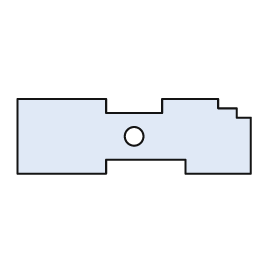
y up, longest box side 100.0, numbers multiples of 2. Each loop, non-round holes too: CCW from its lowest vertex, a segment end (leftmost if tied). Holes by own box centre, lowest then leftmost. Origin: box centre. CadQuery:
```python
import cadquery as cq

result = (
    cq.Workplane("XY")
    .moveTo(-50.0, -16.0)
    .lineTo(-12.0, -16.0)
    .lineTo(-12.0, -10.0)
    .lineTo(22.0, -10.0)
    .lineTo(22.0, -16.0)
    .lineTo(50.0, -16.0)
    .lineTo(50.0, 8.0)
    .lineTo(44.0, 8.0)
    .lineTo(44.0, 12.0)
    .lineTo(36.0, 12.0)
    .lineTo(36.0, 16.0)
    .lineTo(12.0, 16.0)
    .lineTo(12.0, 10.0)
    .lineTo(-12.0, 10.0)
    .lineTo(-12.0, 16.0)
    .lineTo(-50.0, 16.0)
    .close()
    .moveTo(0.0, 0.0)
    .circle(4.0)
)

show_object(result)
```